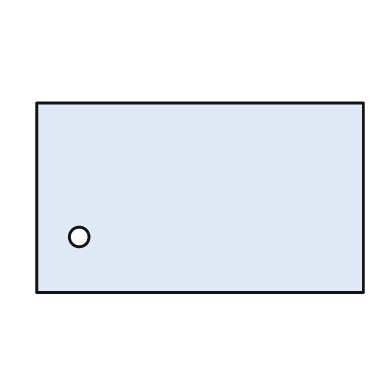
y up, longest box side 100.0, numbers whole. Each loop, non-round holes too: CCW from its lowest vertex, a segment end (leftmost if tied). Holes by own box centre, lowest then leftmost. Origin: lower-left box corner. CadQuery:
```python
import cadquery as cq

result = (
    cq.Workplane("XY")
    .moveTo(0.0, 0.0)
    .lineTo(100.0, 0.0)
    .lineTo(100.0, 58.0)
    .lineTo(0.0, 58.0)
    .close()
    .moveTo(13.0, 17.0)
    .circle(3.0)
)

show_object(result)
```